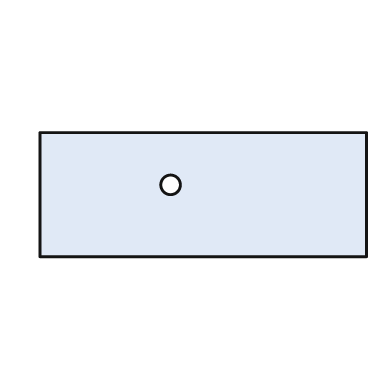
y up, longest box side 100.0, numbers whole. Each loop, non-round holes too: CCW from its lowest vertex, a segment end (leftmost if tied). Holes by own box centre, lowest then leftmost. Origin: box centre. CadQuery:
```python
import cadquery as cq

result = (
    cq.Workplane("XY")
    .moveTo(-50.0, -19.0)
    .lineTo(50.0, -19.0)
    .lineTo(50.0, 19.0)
    .lineTo(-50.0, 19.0)
    .close()
    .moveTo(-10.0, 3.0)
    .circle(3.0)
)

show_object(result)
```